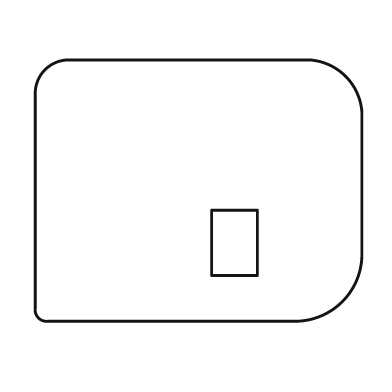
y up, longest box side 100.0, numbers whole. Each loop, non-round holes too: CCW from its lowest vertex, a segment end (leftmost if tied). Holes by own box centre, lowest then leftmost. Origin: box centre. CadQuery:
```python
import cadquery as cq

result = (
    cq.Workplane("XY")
    .moveTo(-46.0, -40.0)
    .lineTo(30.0, -40.0)
    .threePointArc((44.0, -34.0), (50.0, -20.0))
    .lineTo(50.0, 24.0)
    .threePointArc((45.0, 35.0), (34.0, 40.0))
    .lineTo(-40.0, 40.0)
    .threePointArc((-47.0, 37.0), (-50.0, 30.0))
    .lineTo(-50.0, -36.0)
    .threePointArc((-49.0, -39.0), (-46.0, -40.0))
    .close()
    .moveTo(4.0, -26.0)
    .lineTo(18.0, -26.0)
    .lineTo(18.0, -6.0)
    .lineTo(4.0, -6.0)
    .close()
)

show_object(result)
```